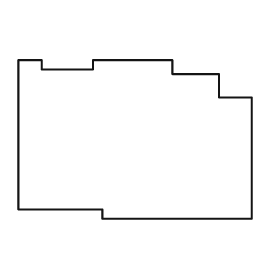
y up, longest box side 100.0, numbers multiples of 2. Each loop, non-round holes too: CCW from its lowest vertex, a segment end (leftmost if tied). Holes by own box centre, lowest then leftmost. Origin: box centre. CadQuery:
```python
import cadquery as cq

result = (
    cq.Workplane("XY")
    .moveTo(-14.0, -34.0)
    .lineTo(50.0, -34.0)
    .lineTo(50.0, 18.0)
    .lineTo(36.0, 18.0)
    .lineTo(36.0, 28.0)
    .lineTo(16.0, 28.0)
    .lineTo(16.0, 34.0)
    .lineTo(-18.0, 34.0)
    .lineTo(-18.0, 30.0)
    .lineTo(-40.0, 30.0)
    .lineTo(-40.0, 34.0)
    .lineTo(-50.0, 34.0)
    .lineTo(-50.0, -30.0)
    .lineTo(-14.0, -30.0)
    .close()
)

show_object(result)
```